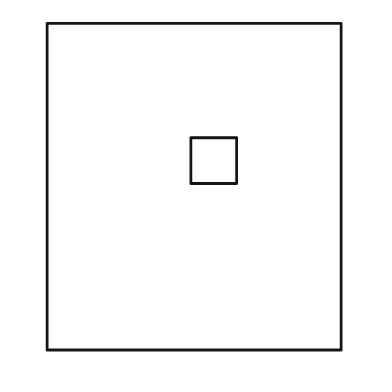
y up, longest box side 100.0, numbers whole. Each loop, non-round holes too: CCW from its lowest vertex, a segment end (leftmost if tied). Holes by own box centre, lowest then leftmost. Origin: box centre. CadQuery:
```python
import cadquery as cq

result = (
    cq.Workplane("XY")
    .moveTo(-45.0, -50.0)
    .lineTo(45.0, -50.0)
    .lineTo(45.0, 50.0)
    .lineTo(-45.0, 50.0)
    .close()
    .moveTo(-1.0, 1.0)
    .lineTo(13.0, 1.0)
    .lineTo(13.0, 15.0)
    .lineTo(-1.0, 15.0)
    .close()
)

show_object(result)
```